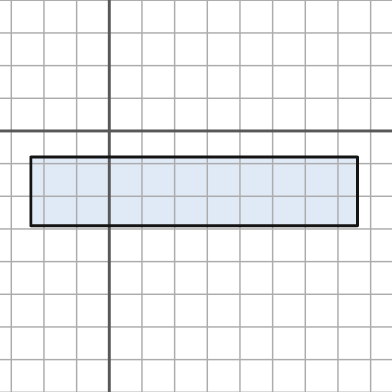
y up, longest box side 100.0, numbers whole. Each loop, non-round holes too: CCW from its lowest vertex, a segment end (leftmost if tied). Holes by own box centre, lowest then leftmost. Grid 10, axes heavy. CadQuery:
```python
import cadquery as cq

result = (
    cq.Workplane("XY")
    .moveTo(-24.0, -29.0)
    .lineTo(76.0, -29.0)
    .lineTo(76.0, -8.0)
    .lineTo(-24.0, -8.0)
    .close()
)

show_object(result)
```